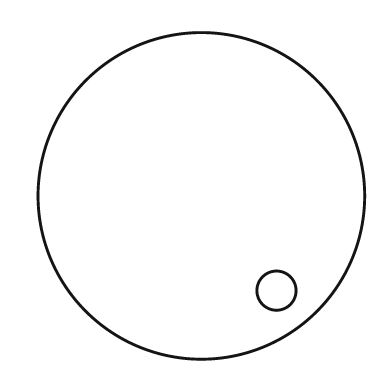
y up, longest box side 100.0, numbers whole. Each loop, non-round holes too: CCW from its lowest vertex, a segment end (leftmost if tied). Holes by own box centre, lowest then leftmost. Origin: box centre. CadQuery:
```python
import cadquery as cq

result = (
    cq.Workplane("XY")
    .moveTo(0.0, 0.0)
    .circle(50.0)
    .moveTo(23.0, -29.0)
    .circle(6.0)
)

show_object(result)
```